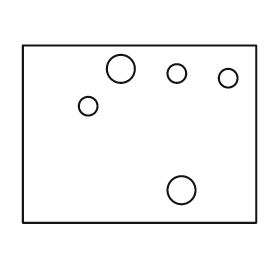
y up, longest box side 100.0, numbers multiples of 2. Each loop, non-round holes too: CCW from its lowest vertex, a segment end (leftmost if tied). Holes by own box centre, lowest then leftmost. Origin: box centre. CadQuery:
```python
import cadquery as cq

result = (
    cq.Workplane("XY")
    .moveTo(-50.0, -38.0)
    .lineTo(50.0, -38.0)
    .lineTo(50.0, 38.0)
    .lineTo(-50.0, 38.0)
    .close()
    .moveTo(18.0, -24.0)
    .circle(6.0)
    .moveTo(-22.0, 12.0)
    .circle(4.0)
    .moveTo(38.0, 24.0)
    .circle(4.0)
    .moveTo(16.0, 26.0)
    .circle(4.0)
    .moveTo(-8.0, 28.0)
    .circle(6.0)
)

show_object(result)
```